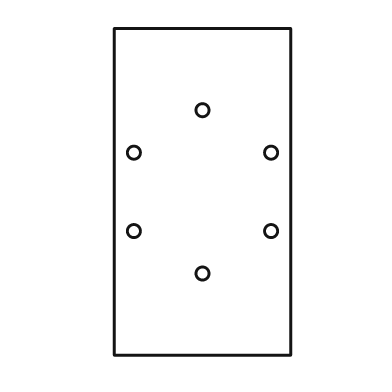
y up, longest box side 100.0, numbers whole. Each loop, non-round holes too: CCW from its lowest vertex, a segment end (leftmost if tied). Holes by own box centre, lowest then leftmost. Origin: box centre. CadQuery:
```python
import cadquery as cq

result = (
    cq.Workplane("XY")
    .moveTo(-27.0, -50.0)
    .lineTo(27.0, -50.0)
    .lineTo(27.0, 50.0)
    .lineTo(-27.0, 50.0)
    .close()
    .moveTo(0.0, -25.0)
    .circle(2.0)
    .moveTo(-21.0, -12.0)
    .circle(2.0)
    .moveTo(21.0, -12.0)
    .circle(2.0)
    .moveTo(-21.0, 12.0)
    .circle(2.0)
    .moveTo(21.0, 12.0)
    .circle(2.0)
    .moveTo(0.0, 25.0)
    .circle(2.0)
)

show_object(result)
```